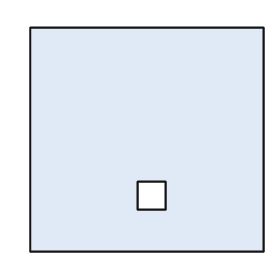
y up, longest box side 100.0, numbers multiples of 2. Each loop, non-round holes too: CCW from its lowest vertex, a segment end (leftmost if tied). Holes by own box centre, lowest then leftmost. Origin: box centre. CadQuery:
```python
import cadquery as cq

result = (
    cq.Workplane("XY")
    .moveTo(-50.0, -48.0)
    .lineTo(50.0, -48.0)
    .lineTo(50.0, 48.0)
    .lineTo(-50.0, 48.0)
    .close()
    .moveTo(-4.0, -30.0)
    .lineTo(8.0, -30.0)
    .lineTo(8.0, -18.0)
    .lineTo(-4.0, -18.0)
    .close()
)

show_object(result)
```